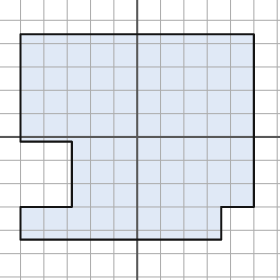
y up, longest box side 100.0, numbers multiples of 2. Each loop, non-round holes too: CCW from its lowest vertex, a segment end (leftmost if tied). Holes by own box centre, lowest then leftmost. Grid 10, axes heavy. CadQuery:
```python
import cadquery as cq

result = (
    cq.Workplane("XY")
    .moveTo(-50.0, -44.0)
    .lineTo(36.0, -44.0)
    .lineTo(36.0, -30.0)
    .lineTo(50.0, -30.0)
    .lineTo(50.0, 44.0)
    .lineTo(-50.0, 44.0)
    .lineTo(-50.0, -2.0)
    .lineTo(-28.0, -2.0)
    .lineTo(-28.0, -30.0)
    .lineTo(-50.0, -30.0)
    .close()
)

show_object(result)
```